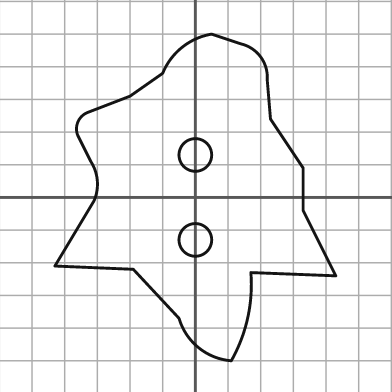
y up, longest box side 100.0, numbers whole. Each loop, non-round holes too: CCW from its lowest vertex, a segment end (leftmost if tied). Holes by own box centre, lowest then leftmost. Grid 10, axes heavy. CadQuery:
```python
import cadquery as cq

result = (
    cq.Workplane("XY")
    .moveTo(11.0, -50.0)
    .threePointArc((16.0, -37.0), (17.0, -23.0))
    .lineTo(43.0, -24.0)
    .lineTo(33.0, -4.0)
    .lineTo(33.0, 9.0)
    .lineTo(23.0, 24.0)
    .lineTo(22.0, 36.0)
    .threePointArc((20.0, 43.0), (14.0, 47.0))
    .lineTo(5.0, 50.0)
    .threePointArc((-4.0, 46.0), (-10.0, 38.0))
    .lineTo(-20.0, 31.0)
    .lineTo(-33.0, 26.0)
    .threePointArc((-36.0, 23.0), (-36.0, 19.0))
    .lineTo(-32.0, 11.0)
    .threePointArc((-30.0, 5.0), (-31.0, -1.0))
    .lineTo(-43.0, -21.0)
    .lineTo(-19.0, -22.0)
    .lineTo(-5.0, -37.0)
    .threePointArc((1.0, -46.0), (11.0, -50.0))
    .close()
    .moveTo(0.0, -13.0)
    .circle(5.0)
    .moveTo(0.0, 13.0)
    .circle(5.0)
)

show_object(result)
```